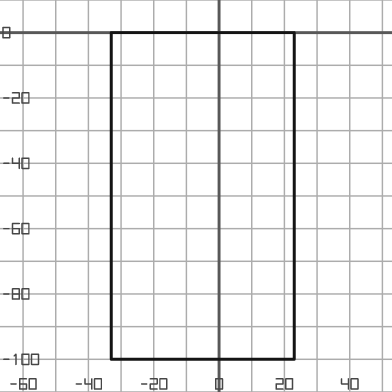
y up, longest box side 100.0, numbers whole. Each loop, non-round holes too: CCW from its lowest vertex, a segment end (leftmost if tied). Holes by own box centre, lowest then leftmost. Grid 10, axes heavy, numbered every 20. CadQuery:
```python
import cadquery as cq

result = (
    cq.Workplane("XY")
    .moveTo(-33.0, -100.0)
    .lineTo(23.0, -100.0)
    .lineTo(23.0, 0.0)
    .lineTo(-33.0, 0.0)
    .close()
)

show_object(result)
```